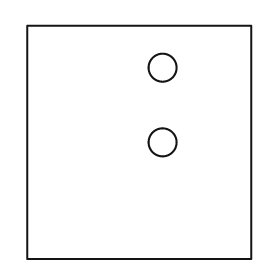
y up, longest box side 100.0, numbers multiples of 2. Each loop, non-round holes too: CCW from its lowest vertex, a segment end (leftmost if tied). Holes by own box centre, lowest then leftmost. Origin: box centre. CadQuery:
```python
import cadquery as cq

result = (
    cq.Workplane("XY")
    .moveTo(-48.0, -50.0)
    .lineTo(48.0, -50.0)
    .lineTo(48.0, 50.0)
    .lineTo(-48.0, 50.0)
    .close()
    .moveTo(10.0, 0.0)
    .circle(6.0)
    .moveTo(10.0, 32.0)
    .circle(6.0)
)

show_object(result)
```